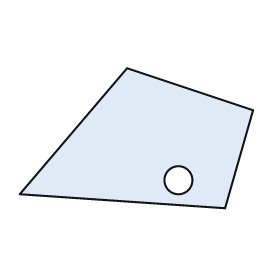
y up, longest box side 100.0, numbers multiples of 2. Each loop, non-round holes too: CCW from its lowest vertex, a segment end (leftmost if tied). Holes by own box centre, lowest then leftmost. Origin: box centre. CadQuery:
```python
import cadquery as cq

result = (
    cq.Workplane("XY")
    .moveTo(38.0, -30.0)
    .lineTo(50.0, 12.0)
    .lineTo(-4.0, 30.0)
    .lineTo(-50.0, -24.0)
    .close()
    .moveTo(18.0, -18.0)
    .circle(6.0)
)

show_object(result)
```